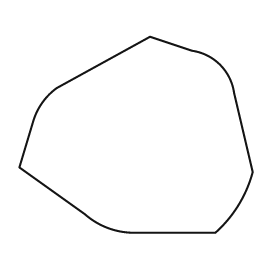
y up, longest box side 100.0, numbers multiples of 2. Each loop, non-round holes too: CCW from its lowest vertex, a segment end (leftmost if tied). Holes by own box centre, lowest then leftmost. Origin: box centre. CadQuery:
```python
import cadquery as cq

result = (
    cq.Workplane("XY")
    .moveTo(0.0, -42.0)
    .lineTo(34.0, -42.0)
    .threePointArc((44.0, -30.0), (50.0, -16.0))
    .lineTo(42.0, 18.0)
    .threePointArc((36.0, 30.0), (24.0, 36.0))
    .lineTo(6.0, 42.0)
    .lineTo(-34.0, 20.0)
    .threePointArc((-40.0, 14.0), (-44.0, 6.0))
    .lineTo(-50.0, -14.0)
    .lineTo(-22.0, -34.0)
    .threePointArc((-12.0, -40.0), (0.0, -42.0))
    .close()
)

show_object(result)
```